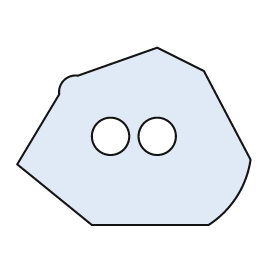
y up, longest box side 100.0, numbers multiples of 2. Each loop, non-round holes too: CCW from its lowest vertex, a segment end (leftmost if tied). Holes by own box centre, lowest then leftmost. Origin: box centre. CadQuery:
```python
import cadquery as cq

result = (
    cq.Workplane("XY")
    .moveTo(-18.0, -38.0)
    .lineTo(32.0, -38.0)
    .threePointArc((44.0, -26.0), (50.0, -10.0))
    .lineTo(30.0, 28.0)
    .lineTo(10.0, 38.0)
    .lineTo(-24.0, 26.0)
    .threePointArc((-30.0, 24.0), (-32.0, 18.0))
    .lineTo(-50.0, -12.0)
    .close()
    .moveTo(-10.0, 0.0)
    .circle(8.0)
    .moveTo(10.0, 0.0)
    .circle(8.0)
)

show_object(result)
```